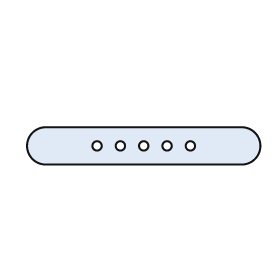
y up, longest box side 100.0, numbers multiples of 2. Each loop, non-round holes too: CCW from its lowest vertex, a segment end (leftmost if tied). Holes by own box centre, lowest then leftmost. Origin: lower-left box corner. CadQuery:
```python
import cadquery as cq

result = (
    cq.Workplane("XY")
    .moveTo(8.0, 0.0)
    .lineTo(92.0, 0.0)
    .threePointArc((100.0, 8.0), (92.0, 16.0))
    .lineTo(8.0, 16.0)
    .threePointArc((0.0, 8.0), (8.0, 0.0))
    .close()
    .moveTo(30.0, 8.0)
    .circle(2.0)
    .moveTo(40.0, 8.0)
    .circle(2.0)
    .moveTo(50.0, 8.0)
    .circle(2.0)
    .moveTo(60.0, 8.0)
    .circle(2.0)
    .moveTo(70.0, 8.0)
    .circle(2.0)
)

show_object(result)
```